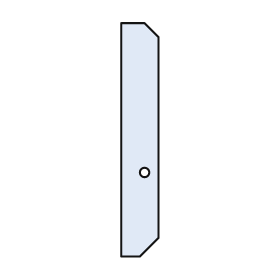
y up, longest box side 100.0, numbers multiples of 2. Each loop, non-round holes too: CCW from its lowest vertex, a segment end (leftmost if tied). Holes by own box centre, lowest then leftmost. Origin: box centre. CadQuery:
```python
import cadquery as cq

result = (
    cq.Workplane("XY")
    .moveTo(-8.0, -50.0)
    .lineTo(0.0, -50.0)
    .lineTo(8.0, -42.0)
    .lineTo(8.0, 44.0)
    .lineTo(2.0, 50.0)
    .lineTo(-8.0, 50.0)
    .close()
    .moveTo(2.0, -14.0)
    .circle(2.0)
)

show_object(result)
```